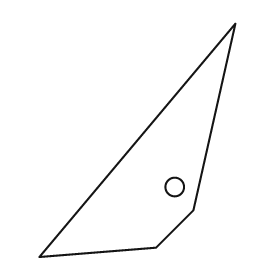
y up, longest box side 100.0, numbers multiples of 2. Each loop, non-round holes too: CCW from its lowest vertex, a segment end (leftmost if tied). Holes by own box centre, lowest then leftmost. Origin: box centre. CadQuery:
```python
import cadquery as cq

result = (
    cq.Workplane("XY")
    .moveTo(-42.0, -50.0)
    .lineTo(8.0, -46.0)
    .lineTo(24.0, -30.0)
    .lineTo(42.0, 50.0)
    .close()
    .moveTo(16.0, -20.0)
    .circle(4.0)
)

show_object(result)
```